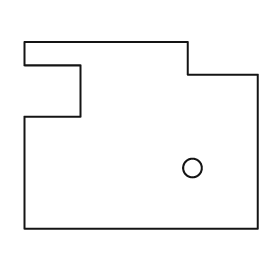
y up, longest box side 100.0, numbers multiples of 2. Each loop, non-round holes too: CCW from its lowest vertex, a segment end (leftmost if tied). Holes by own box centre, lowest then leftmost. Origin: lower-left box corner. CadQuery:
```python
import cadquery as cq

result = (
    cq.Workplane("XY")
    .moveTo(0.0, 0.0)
    .lineTo(100.0, 0.0)
    .lineTo(100.0, 66.0)
    .lineTo(70.0, 66.0)
    .lineTo(70.0, 80.0)
    .lineTo(0.0, 80.0)
    .lineTo(0.0, 70.0)
    .lineTo(24.0, 70.0)
    .lineTo(24.0, 48.0)
    .lineTo(0.0, 48.0)
    .close()
    .moveTo(72.0, 26.0)
    .circle(4.0)
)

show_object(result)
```